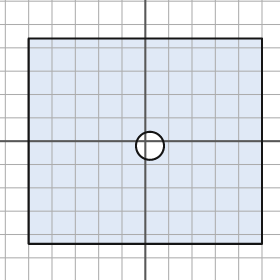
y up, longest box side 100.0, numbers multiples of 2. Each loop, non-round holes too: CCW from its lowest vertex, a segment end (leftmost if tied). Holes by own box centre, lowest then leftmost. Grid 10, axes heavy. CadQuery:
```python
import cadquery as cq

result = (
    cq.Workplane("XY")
    .moveTo(-50.0, -44.0)
    .lineTo(50.0, -44.0)
    .lineTo(50.0, 44.0)
    .lineTo(-50.0, 44.0)
    .close()
    .moveTo(2.0, -2.0)
    .circle(6.0)
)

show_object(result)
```